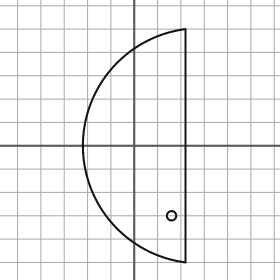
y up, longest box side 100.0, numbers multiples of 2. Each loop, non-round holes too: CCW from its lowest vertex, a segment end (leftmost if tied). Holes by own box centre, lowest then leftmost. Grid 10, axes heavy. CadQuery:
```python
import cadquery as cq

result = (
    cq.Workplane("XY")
    .moveTo(22.0, -50.0)
    .lineTo(22.0, 50.0)
    .threePointArc((-22.0, 0.0), (22.0, -50.0))
    .close()
    .moveTo(16.0, -30.0)
    .circle(2.0)
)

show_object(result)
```